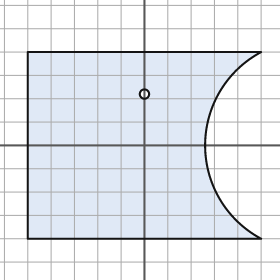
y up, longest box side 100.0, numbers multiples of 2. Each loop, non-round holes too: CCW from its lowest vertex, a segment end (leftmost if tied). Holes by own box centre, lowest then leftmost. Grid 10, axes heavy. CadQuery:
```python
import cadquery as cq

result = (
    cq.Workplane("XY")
    .moveTo(-50.0, -40.0)
    .lineTo(50.0, -40.0)
    .threePointArc((26.0, 0.0), (50.0, 40.0))
    .lineTo(-50.0, 40.0)
    .close()
    .moveTo(0.0, 22.0)
    .circle(2.0)
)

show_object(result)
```